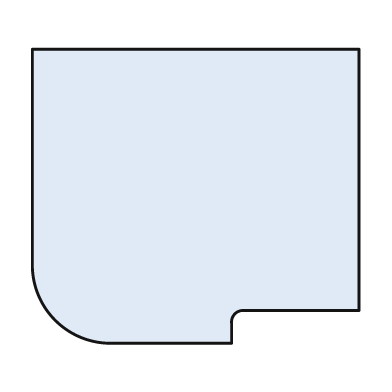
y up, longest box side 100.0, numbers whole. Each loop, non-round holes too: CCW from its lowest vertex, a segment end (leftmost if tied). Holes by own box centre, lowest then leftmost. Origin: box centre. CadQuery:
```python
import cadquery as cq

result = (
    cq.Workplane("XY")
    .moveTo(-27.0, -45.0)
    .lineTo(11.0, -45.0)
    .lineTo(11.0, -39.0)
    .threePointArc((12.0, -36.0), (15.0, -35.0))
    .lineTo(50.0, -35.0)
    .lineTo(50.0, 45.0)
    .lineTo(-50.0, 45.0)
    .lineTo(-50.0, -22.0)
    .threePointArc((-43.0, -38.0), (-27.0, -45.0))
    .close()
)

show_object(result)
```